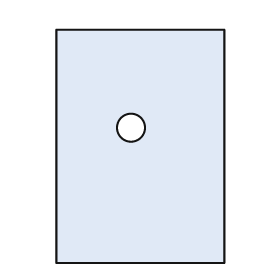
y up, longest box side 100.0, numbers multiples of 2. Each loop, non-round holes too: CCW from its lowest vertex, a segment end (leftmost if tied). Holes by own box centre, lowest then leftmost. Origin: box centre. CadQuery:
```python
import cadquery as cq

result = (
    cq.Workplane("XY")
    .moveTo(-36.0, -50.0)
    .lineTo(36.0, -50.0)
    .lineTo(36.0, 50.0)
    .lineTo(-36.0, 50.0)
    .close()
    .moveTo(-4.0, 8.0)
    .circle(6.0)
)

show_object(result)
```